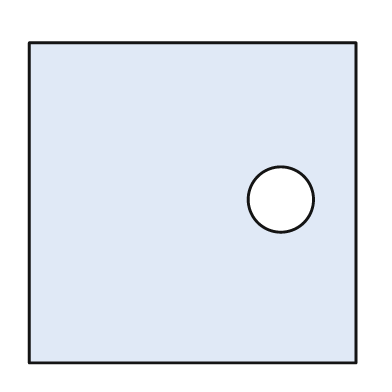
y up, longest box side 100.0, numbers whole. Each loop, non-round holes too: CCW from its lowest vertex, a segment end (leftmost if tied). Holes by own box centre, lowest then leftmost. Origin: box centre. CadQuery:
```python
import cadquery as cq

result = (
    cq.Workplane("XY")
    .moveTo(-50.0, -49.0)
    .lineTo(50.0, -49.0)
    .lineTo(50.0, 49.0)
    .lineTo(-50.0, 49.0)
    .close()
    .moveTo(27.0, 1.0)
    .circle(10.0)
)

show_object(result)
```